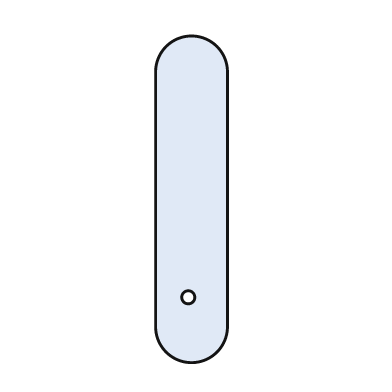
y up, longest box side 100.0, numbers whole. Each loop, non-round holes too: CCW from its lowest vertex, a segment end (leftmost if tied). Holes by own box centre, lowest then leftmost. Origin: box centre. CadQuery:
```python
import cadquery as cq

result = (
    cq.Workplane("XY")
    .moveTo(-11.0, -39.0)
    .threePointArc((0.0, -50.0), (11.0, -39.0))
    .lineTo(11.0, 39.0)
    .threePointArc((0.0, 50.0), (-11.0, 39.0))
    .close()
    .moveTo(-1.0, -30.0)
    .circle(2.0)
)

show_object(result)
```